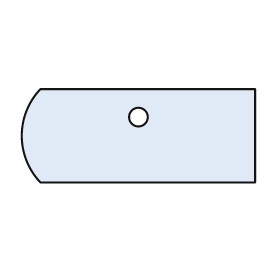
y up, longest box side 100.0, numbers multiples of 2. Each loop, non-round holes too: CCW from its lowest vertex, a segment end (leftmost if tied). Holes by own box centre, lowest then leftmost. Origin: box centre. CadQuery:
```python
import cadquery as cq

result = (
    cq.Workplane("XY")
    .moveTo(-42.0, -20.0)
    .lineTo(50.0, -20.0)
    .lineTo(50.0, 20.0)
    .lineTo(-42.0, 20.0)
    .threePointArc((-50.0, 0.0), (-42.0, -20.0))
    .close()
    .moveTo(0.0, 8.0)
    .circle(4.0)
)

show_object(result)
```